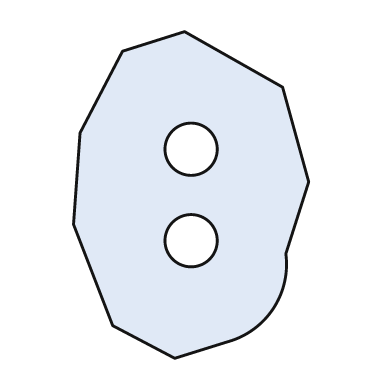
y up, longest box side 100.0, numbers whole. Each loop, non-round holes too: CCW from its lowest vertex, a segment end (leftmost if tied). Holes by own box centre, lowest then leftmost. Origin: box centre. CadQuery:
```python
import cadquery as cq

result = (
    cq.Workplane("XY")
    .moveTo(-5.0, -50.0)
    .lineTo(11.0, -45.0)
    .threePointArc((25.0, -35.0), (29.0, -18.0))
    .lineTo(36.0, 4.0)
    .lineTo(28.0, 33.0)
    .lineTo(-2.0, 50.0)
    .lineTo(-21.0, 44.0)
    .lineTo(-34.0, 19.0)
    .lineTo(-36.0, -9.0)
    .lineTo(-24.0, -40.0)
    .close()
    .moveTo(0.0, -14.0)
    .circle(8.0)
    .moveTo(0.0, 14.0)
    .circle(8.0)
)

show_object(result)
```